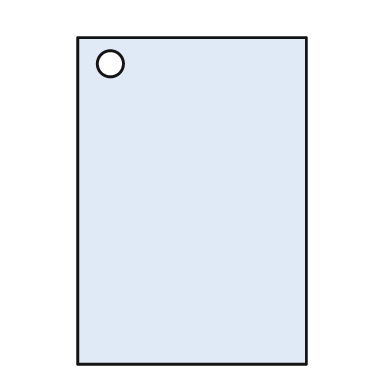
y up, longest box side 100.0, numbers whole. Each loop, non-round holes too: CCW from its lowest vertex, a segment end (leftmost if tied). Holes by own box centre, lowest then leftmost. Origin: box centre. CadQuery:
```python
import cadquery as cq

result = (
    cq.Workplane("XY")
    .moveTo(-35.0, -50.0)
    .lineTo(35.0, -50.0)
    .lineTo(35.0, 50.0)
    .lineTo(-35.0, 50.0)
    .close()
    .moveTo(-25.0, 42.0)
    .circle(4.0)
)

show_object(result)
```